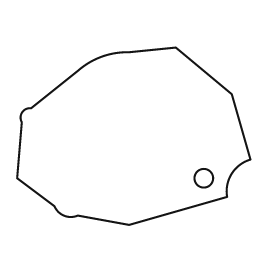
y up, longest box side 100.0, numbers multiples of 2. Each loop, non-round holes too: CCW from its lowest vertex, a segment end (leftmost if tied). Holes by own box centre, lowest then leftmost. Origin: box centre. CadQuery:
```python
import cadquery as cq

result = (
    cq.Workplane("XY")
    .moveTo(-2.0, -38.0)
    .lineTo(40.0, -26.0)
    .threePointArc((42.0, -16.0), (50.0, -10.0))
    .lineTo(42.0, 18.0)
    .lineTo(18.0, 38.0)
    .lineTo(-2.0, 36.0)
    .threePointArc((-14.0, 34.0), (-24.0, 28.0))
    .lineTo(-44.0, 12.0)
    .threePointArc((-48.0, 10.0), (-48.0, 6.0))
    .lineTo(-50.0, -18.0)
    .lineTo(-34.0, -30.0)
    .threePointArc((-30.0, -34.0), (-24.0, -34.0))
    .close()
    .moveTo(30.0, -18.0)
    .circle(4.0)
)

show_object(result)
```